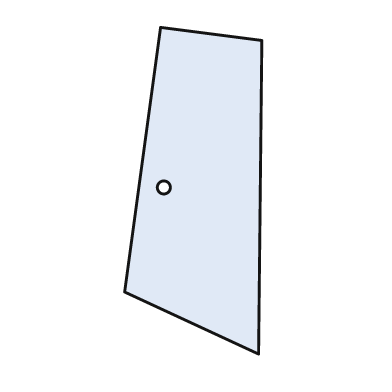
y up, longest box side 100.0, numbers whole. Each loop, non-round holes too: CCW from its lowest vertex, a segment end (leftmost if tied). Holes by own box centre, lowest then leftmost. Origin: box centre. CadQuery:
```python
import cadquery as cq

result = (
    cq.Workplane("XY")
    .moveTo(20.0, -50.0)
    .lineTo(21.0, 46.0)
    .lineTo(-10.0, 50.0)
    .lineTo(-21.0, -31.0)
    .close()
    .moveTo(-9.0, 1.0)
    .circle(2.0)
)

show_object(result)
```